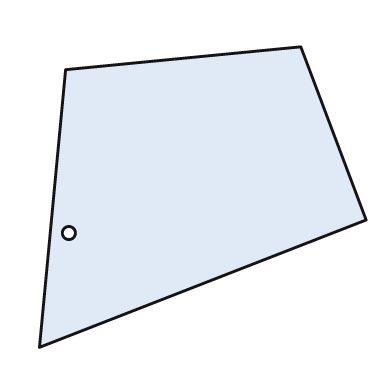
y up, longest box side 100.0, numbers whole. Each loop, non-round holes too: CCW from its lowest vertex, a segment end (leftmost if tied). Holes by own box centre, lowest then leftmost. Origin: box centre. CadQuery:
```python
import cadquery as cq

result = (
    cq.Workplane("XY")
    .moveTo(-50.0, -46.0)
    .lineTo(50.0, -7.0)
    .lineTo(30.0, 46.0)
    .lineTo(-42.0, 39.0)
    .close()
    .moveTo(-41.0, -11.0)
    .circle(2.0)
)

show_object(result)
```